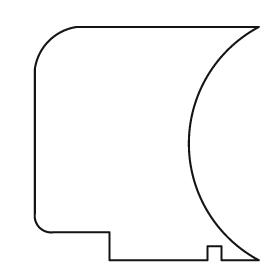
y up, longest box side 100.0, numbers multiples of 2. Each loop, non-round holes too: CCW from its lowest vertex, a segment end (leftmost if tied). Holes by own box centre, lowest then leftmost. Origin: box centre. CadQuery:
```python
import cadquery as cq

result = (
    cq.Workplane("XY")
    .moveTo(-16.0, -50.0)
    .lineTo(26.0, -50.0)
    .lineTo(26.0, -44.0)
    .lineTo(32.0, -44.0)
    .lineTo(32.0, -50.0)
    .lineTo(48.0, -50.0)
    .threePointArc((18.0, 0.0), (48.0, 50.0))
    .lineTo(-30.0, 50.0)
    .threePointArc((-42.0, 44.0), (-48.0, 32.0))
    .lineTo(-48.0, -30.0)
    .threePointArc((-46.0, -36.0), (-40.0, -38.0))
    .lineTo(-16.0, -38.0)
    .close()
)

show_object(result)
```